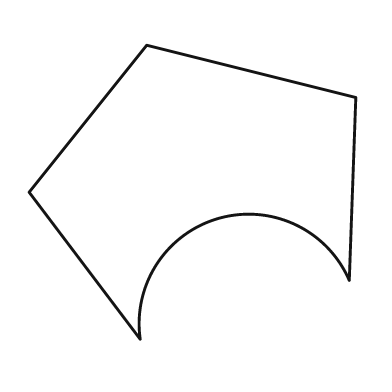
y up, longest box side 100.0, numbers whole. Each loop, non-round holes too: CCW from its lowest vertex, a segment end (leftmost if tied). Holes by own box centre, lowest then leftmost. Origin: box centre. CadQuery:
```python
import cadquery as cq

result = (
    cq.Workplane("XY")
    .moveTo(-16.0, -45.0)
    .threePointArc((8.0, -8.0), (48.0, -27.0))
    .lineTo(50.0, 29.0)
    .lineTo(-14.0, 45.0)
    .lineTo(-50.0, 0.0)
    .close()
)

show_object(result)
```